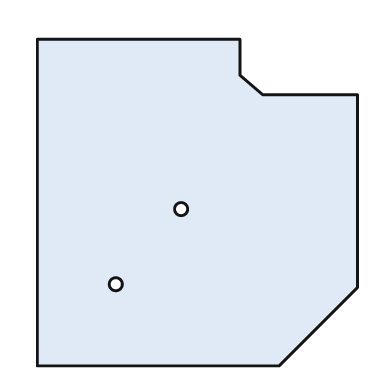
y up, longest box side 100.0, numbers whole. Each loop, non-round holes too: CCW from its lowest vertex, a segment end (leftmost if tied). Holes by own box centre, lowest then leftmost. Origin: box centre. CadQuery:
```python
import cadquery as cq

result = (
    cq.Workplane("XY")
    .moveTo(-49.0, -50.0)
    .lineTo(25.0, -50.0)
    .lineTo(49.0, -26.0)
    .lineTo(49.0, 33.0)
    .lineTo(20.0, 33.0)
    .lineTo(13.0, 39.0)
    .lineTo(13.0, 50.0)
    .lineTo(-49.0, 50.0)
    .close()
    .moveTo(-25.0, -25.0)
    .circle(2.0)
    .moveTo(-5.0, -2.0)
    .circle(2.0)
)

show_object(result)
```